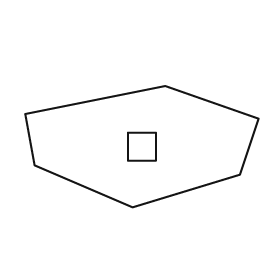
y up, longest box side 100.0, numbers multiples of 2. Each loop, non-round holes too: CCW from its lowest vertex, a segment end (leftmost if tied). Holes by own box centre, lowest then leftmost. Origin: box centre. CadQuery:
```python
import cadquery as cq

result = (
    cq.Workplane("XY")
    .moveTo(-4.0, -26.0)
    .lineTo(42.0, -12.0)
    .lineTo(50.0, 12.0)
    .lineTo(10.0, 26.0)
    .lineTo(-50.0, 14.0)
    .lineTo(-46.0, -8.0)
    .close()
    .moveTo(-6.0, -6.0)
    .lineTo(6.0, -6.0)
    .lineTo(6.0, 6.0)
    .lineTo(-6.0, 6.0)
    .close()
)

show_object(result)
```